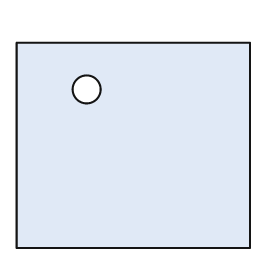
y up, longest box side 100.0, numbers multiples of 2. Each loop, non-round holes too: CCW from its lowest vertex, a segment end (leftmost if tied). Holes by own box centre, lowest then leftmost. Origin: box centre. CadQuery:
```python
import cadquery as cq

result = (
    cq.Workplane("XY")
    .moveTo(-50.0, -44.0)
    .lineTo(50.0, -44.0)
    .lineTo(50.0, 44.0)
    .lineTo(-50.0, 44.0)
    .close()
    .moveTo(-20.0, 24.0)
    .circle(6.0)
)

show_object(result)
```